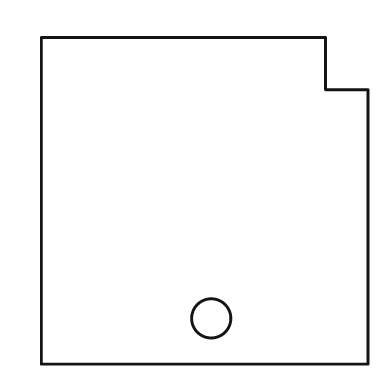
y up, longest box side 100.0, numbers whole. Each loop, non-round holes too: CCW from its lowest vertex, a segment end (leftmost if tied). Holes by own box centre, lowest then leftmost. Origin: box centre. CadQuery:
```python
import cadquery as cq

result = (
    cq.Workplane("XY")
    .moveTo(-50.0, -50.0)
    .lineTo(50.0, -50.0)
    .lineTo(50.0, 34.0)
    .lineTo(37.0, 34.0)
    .lineTo(37.0, 50.0)
    .lineTo(-50.0, 50.0)
    .close()
    .moveTo(2.0, -36.0)
    .circle(6.0)
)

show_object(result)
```